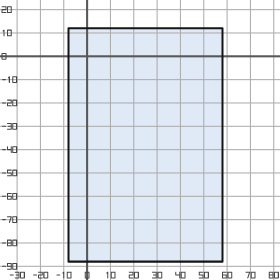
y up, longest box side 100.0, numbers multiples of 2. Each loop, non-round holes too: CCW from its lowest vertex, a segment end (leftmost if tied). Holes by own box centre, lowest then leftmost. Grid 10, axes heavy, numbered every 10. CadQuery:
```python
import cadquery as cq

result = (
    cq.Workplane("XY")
    .moveTo(-8.0, -88.0)
    .lineTo(58.0, -88.0)
    .lineTo(58.0, 12.0)
    .lineTo(-8.0, 12.0)
    .close()
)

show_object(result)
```